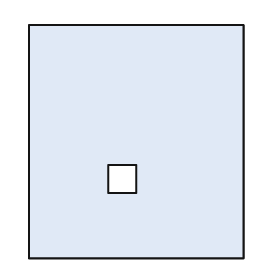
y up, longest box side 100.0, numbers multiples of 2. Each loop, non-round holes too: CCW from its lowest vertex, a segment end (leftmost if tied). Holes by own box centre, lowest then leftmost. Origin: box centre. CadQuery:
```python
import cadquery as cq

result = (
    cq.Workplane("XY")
    .moveTo(-46.0, -50.0)
    .lineTo(46.0, -50.0)
    .lineTo(46.0, 50.0)
    .lineTo(-46.0, 50.0)
    .close()
    .moveTo(-12.0, -22.0)
    .lineTo(0.0, -22.0)
    .lineTo(0.0, -10.0)
    .lineTo(-12.0, -10.0)
    .close()
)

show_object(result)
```